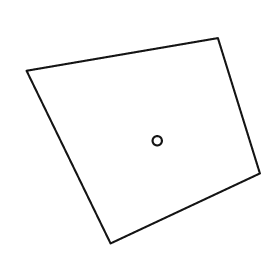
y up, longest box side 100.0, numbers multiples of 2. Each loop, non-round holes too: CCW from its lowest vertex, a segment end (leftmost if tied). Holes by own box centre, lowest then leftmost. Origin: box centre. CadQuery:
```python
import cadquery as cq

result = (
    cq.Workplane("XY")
    .moveTo(-14.0, -44.0)
    .lineTo(50.0, -14.0)
    .lineTo(32.0, 44.0)
    .lineTo(-50.0, 30.0)
    .close()
    .moveTo(6.0, 0.0)
    .circle(2.0)
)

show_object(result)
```